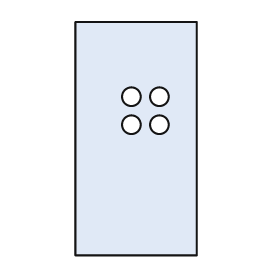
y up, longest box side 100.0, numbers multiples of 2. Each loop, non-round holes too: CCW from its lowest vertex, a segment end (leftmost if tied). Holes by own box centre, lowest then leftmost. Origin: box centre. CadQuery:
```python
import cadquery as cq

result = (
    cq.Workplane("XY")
    .moveTo(-26.0, -50.0)
    .lineTo(26.0, -50.0)
    .lineTo(26.0, 50.0)
    .lineTo(-26.0, 50.0)
    .close()
    .moveTo(-2.0, 6.0)
    .circle(4.0)
    .moveTo(10.0, 6.0)
    .circle(4.0)
    .moveTo(-2.0, 18.0)
    .circle(4.0)
    .moveTo(10.0, 18.0)
    .circle(4.0)
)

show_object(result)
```